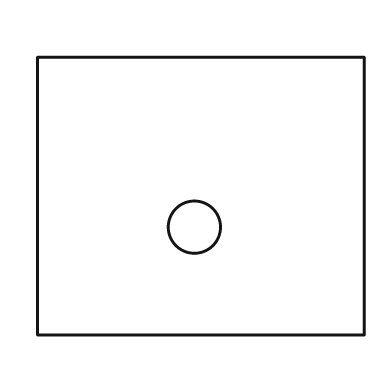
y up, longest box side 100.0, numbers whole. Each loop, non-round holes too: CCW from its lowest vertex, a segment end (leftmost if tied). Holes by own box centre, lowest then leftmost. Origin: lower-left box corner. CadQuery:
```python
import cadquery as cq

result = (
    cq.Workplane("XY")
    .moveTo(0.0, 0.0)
    .lineTo(100.0, 0.0)
    .lineTo(100.0, 85.0)
    .lineTo(0.0, 85.0)
    .close()
    .moveTo(48.0, 33.0)
    .circle(8.0)
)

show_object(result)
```